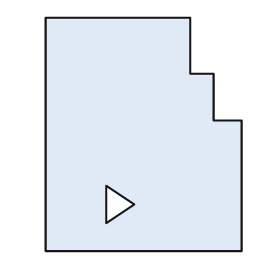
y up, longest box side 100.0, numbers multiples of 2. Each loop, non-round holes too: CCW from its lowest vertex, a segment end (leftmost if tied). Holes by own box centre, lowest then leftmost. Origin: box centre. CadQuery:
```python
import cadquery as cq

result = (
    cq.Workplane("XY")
    .moveTo(-42.0, -50.0)
    .lineTo(42.0, -50.0)
    .lineTo(42.0, 6.0)
    .lineTo(30.0, 6.0)
    .lineTo(30.0, 26.0)
    .lineTo(20.0, 26.0)
    .lineTo(20.0, 50.0)
    .lineTo(-42.0, 50.0)
    .close()
    .moveTo(-16.0, -38.0)
    .lineTo(-4.0, -30.0)
    .lineTo(-16.0, -22.0)
    .close()
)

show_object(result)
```